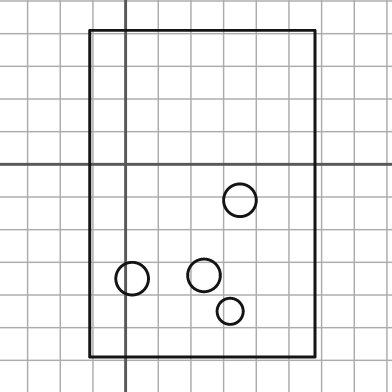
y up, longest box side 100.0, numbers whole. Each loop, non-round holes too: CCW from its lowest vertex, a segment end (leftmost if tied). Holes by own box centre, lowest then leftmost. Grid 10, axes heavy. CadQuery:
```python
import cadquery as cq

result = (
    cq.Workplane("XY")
    .moveTo(-11.0, -59.0)
    .lineTo(58.0, -59.0)
    .lineTo(58.0, 41.0)
    .lineTo(-11.0, 41.0)
    .close()
    .moveTo(32.0, -45.0)
    .circle(4.0)
    .moveTo(2.0, -35.0)
    .circle(5.0)
    .moveTo(24.0, -34.0)
    .circle(5.0)
    .moveTo(35.0, -11.0)
    .circle(5.0)
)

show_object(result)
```